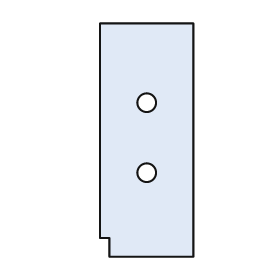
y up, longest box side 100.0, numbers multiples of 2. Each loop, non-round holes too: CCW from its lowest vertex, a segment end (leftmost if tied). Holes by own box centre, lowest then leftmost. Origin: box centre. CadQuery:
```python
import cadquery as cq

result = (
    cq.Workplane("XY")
    .moveTo(-16.0, -50.0)
    .lineTo(20.0, -50.0)
    .lineTo(20.0, 50.0)
    .lineTo(-20.0, 50.0)
    .lineTo(-20.0, -42.0)
    .lineTo(-16.0, -42.0)
    .close()
    .moveTo(0.0, -14.0)
    .circle(4.0)
    .moveTo(0.0, 16.0)
    .circle(4.0)
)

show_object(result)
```